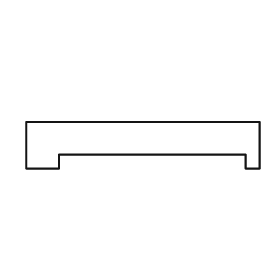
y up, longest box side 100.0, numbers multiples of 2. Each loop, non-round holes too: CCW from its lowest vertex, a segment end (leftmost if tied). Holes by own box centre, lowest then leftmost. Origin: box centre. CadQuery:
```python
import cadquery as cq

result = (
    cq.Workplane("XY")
    .moveTo(-50.0, -10.0)
    .lineTo(-36.0, -10.0)
    .lineTo(-36.0, -4.0)
    .lineTo(44.0, -4.0)
    .lineTo(44.0, -10.0)
    .lineTo(50.0, -10.0)
    .lineTo(50.0, 10.0)
    .lineTo(-50.0, 10.0)
    .close()
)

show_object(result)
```